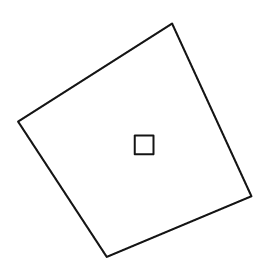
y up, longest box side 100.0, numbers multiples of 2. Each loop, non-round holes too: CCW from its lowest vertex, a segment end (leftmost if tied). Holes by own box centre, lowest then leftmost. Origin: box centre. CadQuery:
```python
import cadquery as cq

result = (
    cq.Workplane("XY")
    .moveTo(-12.0, -50.0)
    .lineTo(50.0, -24.0)
    .lineTo(16.0, 50.0)
    .lineTo(-50.0, 8.0)
    .close()
    .moveTo(0.0, -6.0)
    .lineTo(8.0, -6.0)
    .lineTo(8.0, 2.0)
    .lineTo(0.0, 2.0)
    .close()
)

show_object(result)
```